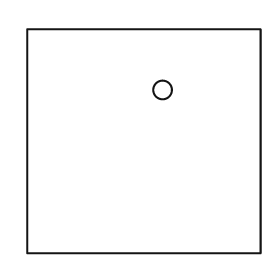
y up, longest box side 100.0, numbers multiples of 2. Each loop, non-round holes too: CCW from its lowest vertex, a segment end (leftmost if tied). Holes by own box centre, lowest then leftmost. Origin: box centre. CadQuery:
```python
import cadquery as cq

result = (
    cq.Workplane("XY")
    .moveTo(-50.0, -48.0)
    .lineTo(50.0, -48.0)
    .lineTo(50.0, 48.0)
    .lineTo(-50.0, 48.0)
    .close()
    .moveTo(8.0, 22.0)
    .circle(4.0)
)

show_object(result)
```